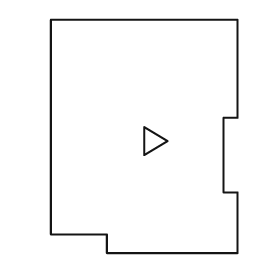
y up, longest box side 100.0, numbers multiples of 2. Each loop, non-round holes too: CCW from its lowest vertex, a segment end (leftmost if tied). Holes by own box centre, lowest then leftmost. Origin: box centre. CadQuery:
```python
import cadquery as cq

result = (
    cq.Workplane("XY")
    .moveTo(-16.0, -50.0)
    .lineTo(40.0, -50.0)
    .lineTo(40.0, -24.0)
    .lineTo(34.0, -24.0)
    .lineTo(34.0, 8.0)
    .lineTo(40.0, 8.0)
    .lineTo(40.0, 50.0)
    .lineTo(-40.0, 50.0)
    .lineTo(-40.0, -42.0)
    .lineTo(-16.0, -42.0)
    .close()
    .moveTo(0.0, -8.0)
    .lineTo(10.0, -2.0)
    .lineTo(0.0, 4.0)
    .close()
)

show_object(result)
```